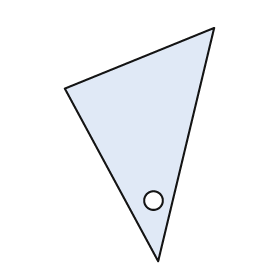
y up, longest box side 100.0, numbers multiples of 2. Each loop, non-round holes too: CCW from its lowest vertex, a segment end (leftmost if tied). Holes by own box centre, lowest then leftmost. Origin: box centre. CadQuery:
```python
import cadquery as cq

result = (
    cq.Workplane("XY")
    .moveTo(8.0, -50.0)
    .lineTo(32.0, 50.0)
    .lineTo(-32.0, 24.0)
    .close()
    .moveTo(6.0, -24.0)
    .circle(4.0)
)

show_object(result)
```